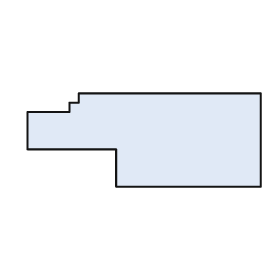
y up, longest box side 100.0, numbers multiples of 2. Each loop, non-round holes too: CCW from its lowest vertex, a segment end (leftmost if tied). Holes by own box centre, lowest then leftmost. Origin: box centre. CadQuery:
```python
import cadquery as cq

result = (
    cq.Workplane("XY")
    .moveTo(-12.0, -20.0)
    .lineTo(50.0, -20.0)
    .lineTo(50.0, 20.0)
    .lineTo(-28.0, 20.0)
    .lineTo(-28.0, 16.0)
    .lineTo(-32.0, 16.0)
    .lineTo(-32.0, 12.0)
    .lineTo(-50.0, 12.0)
    .lineTo(-50.0, -4.0)
    .lineTo(-12.0, -4.0)
    .close()
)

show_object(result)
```